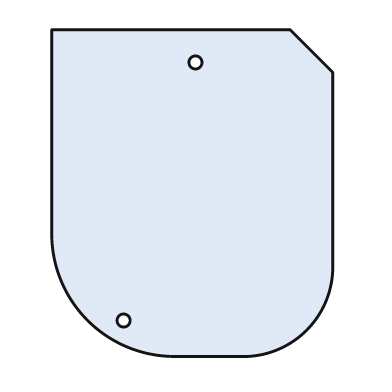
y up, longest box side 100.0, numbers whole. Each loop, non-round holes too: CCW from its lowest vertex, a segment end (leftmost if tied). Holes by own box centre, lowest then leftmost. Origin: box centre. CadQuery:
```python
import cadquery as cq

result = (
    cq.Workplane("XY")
    .moveTo(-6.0, -50.0)
    .lineTo(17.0, -50.0)
    .threePointArc((35.0, -42.0), (43.0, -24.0))
    .lineTo(43.0, 37.0)
    .lineTo(30.0, 50.0)
    .lineTo(-43.0, 50.0)
    .lineTo(-43.0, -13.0)
    .threePointArc((-32.0, -39.0), (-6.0, -50.0))
    .close()
    .moveTo(-21.0, -39.0)
    .circle(2.0)
    .moveTo(1.0, 40.0)
    .circle(2.0)
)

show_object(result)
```